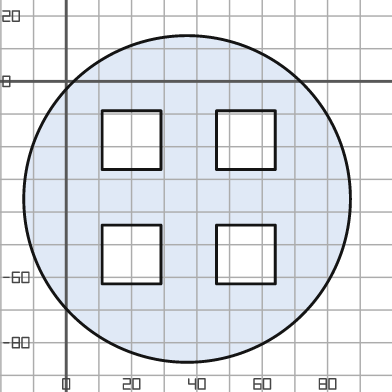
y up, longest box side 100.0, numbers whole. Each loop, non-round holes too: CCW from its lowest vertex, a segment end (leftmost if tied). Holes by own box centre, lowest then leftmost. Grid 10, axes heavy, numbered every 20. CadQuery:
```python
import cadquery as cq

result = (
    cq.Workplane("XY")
    .moveTo(37.0, -36.0)
    .circle(50.0)
    .moveTo(11.0, -62.0)
    .lineTo(29.0, -62.0)
    .lineTo(29.0, -44.0)
    .lineTo(11.0, -44.0)
    .close()
    .moveTo(46.0, -62.0)
    .lineTo(64.0, -62.0)
    .lineTo(64.0, -44.0)
    .lineTo(46.0, -44.0)
    .close()
    .moveTo(11.0, -27.0)
    .lineTo(29.0, -27.0)
    .lineTo(29.0, -9.0)
    .lineTo(11.0, -9.0)
    .close()
    .moveTo(46.0, -27.0)
    .lineTo(64.0, -27.0)
    .lineTo(64.0, -9.0)
    .lineTo(46.0, -9.0)
    .close()
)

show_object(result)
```